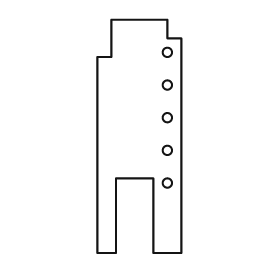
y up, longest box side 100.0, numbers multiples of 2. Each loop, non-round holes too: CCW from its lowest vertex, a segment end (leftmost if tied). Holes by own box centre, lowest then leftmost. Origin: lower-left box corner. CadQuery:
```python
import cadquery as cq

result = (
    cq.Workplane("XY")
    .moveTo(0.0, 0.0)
    .lineTo(8.0, 0.0)
    .lineTo(8.0, 32.0)
    .lineTo(24.0, 32.0)
    .lineTo(24.0, 0.0)
    .lineTo(36.0, 0.0)
    .lineTo(36.0, 92.0)
    .lineTo(30.0, 92.0)
    .lineTo(30.0, 100.0)
    .lineTo(6.0, 100.0)
    .lineTo(6.0, 84.0)
    .lineTo(0.0, 84.0)
    .close()
    .moveTo(30.0, 30.0)
    .circle(2.0)
    .moveTo(30.0, 44.0)
    .circle(2.0)
    .moveTo(30.0, 58.0)
    .circle(2.0)
    .moveTo(30.0, 72.0)
    .circle(2.0)
    .moveTo(30.0, 86.0)
    .circle(2.0)
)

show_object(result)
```